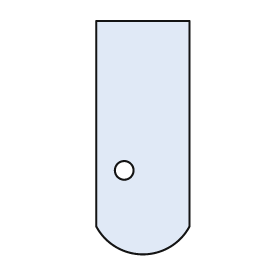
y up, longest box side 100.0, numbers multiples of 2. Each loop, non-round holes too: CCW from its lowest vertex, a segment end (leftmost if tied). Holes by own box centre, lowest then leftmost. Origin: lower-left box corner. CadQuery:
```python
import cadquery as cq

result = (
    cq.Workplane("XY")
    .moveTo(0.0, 12.0)
    .threePointArc((20.0, 0.0), (40.0, 12.0))
    .lineTo(40.0, 100.0)
    .lineTo(0.0, 100.0)
    .close()
    .moveTo(12.0, 36.0)
    .circle(4.0)
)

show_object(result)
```